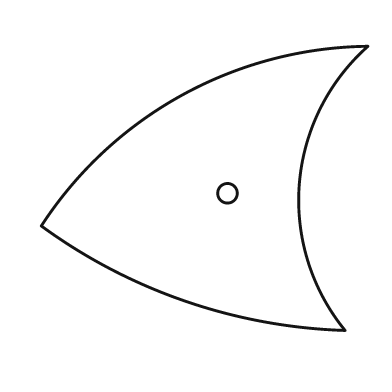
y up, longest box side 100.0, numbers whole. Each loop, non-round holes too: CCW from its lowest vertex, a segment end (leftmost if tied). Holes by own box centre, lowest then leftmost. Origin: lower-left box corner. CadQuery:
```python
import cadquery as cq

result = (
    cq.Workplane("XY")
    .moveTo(93.0, 0.0)
    .threePointArc((79.0, 45.0), (100.0, 87.0))
    .threePointArc((43.0, 72.0), (0.0, 32.0))
    .threePointArc((44.0, 9.0), (93.0, 0.0))
    .close()
    .moveTo(57.0, 42.0)
    .circle(3.0)
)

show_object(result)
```